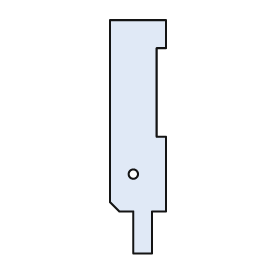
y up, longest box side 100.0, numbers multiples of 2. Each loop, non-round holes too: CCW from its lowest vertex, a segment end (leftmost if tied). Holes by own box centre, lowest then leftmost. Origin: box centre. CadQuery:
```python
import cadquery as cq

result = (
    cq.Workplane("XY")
    .moveTo(-2.0, -50.0)
    .lineTo(6.0, -50.0)
    .lineTo(6.0, -32.0)
    .lineTo(12.0, -32.0)
    .lineTo(12.0, 0.0)
    .lineTo(8.0, 0.0)
    .lineTo(8.0, 38.0)
    .lineTo(12.0, 38.0)
    .lineTo(12.0, 50.0)
    .lineTo(-12.0, 50.0)
    .lineTo(-12.0, -28.0)
    .lineTo(-8.0, -32.0)
    .lineTo(-2.0, -32.0)
    .close()
    .moveTo(-2.0, -16.0)
    .circle(2.0)
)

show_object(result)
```